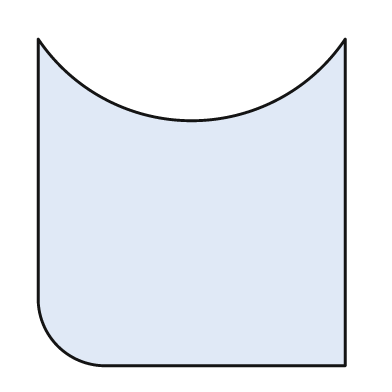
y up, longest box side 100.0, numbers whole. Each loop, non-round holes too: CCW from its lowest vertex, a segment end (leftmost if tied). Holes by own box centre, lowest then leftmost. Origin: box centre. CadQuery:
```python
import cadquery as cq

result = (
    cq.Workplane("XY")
    .moveTo(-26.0, -50.0)
    .lineTo(47.0, -50.0)
    .lineTo(47.0, 50.0)
    .threePointArc((0.0, 25.0), (-47.0, 50.0))
    .lineTo(-47.0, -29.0)
    .threePointArc((-41.0, -44.0), (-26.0, -50.0))
    .close()
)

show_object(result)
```